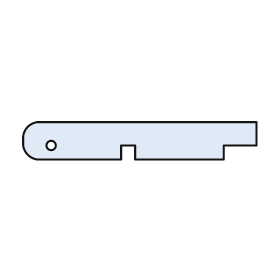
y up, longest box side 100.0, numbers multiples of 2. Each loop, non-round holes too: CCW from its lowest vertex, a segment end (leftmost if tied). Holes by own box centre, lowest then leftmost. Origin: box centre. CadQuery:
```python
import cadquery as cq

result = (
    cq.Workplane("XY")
    .moveTo(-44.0, -8.0)
    .lineTo(-8.0, -8.0)
    .lineTo(-8.0, -2.0)
    .lineTo(-2.0, -2.0)
    .lineTo(-2.0, -8.0)
    .lineTo(36.0, -8.0)
    .lineTo(36.0, -2.0)
    .lineTo(50.0, -2.0)
    .lineTo(50.0, 8.0)
    .lineTo(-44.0, 8.0)
    .threePointArc((-48.0, 6.0), (-50.0, 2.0))
    .lineTo(-50.0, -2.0)
    .threePointArc((-48.0, -6.0), (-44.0, -8.0))
    .close()
    .moveTo(-38.0, -2.0)
    .circle(2.0)
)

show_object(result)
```